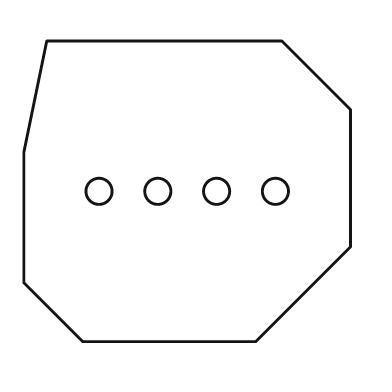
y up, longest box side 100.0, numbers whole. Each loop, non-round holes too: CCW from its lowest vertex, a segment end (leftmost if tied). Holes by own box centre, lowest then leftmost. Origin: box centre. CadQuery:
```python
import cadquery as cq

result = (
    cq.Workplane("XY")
    .moveTo(-32.0, -46.0)
    .lineTo(21.0, -46.0)
    .lineTo(50.0, -17.0)
    .lineTo(50.0, 25.0)
    .lineTo(29.0, 46.0)
    .lineTo(-43.0, 46.0)
    .lineTo(-50.0, 12.0)
    .lineTo(-50.0, -28.0)
    .close()
    .moveTo(-27.0, 0.0)
    .circle(4.0)
    .moveTo(-9.0, 0.0)
    .circle(4.0)
    .moveTo(9.0, 0.0)
    .circle(4.0)
    .moveTo(27.0, 0.0)
    .circle(4.0)
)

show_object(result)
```